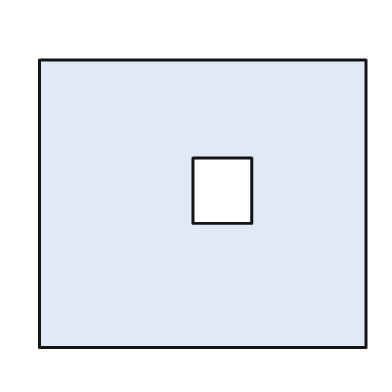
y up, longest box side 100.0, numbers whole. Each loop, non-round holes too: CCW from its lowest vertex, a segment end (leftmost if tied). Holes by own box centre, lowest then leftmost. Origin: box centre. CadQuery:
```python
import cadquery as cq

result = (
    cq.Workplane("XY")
    .moveTo(-50.0, -44.0)
    .lineTo(50.0, -44.0)
    .lineTo(50.0, 44.0)
    .lineTo(-50.0, 44.0)
    .close()
    .moveTo(-3.0, -6.0)
    .lineTo(15.0, -6.0)
    .lineTo(15.0, 14.0)
    .lineTo(-3.0, 14.0)
    .close()
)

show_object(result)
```